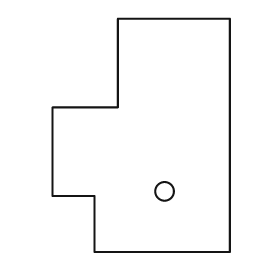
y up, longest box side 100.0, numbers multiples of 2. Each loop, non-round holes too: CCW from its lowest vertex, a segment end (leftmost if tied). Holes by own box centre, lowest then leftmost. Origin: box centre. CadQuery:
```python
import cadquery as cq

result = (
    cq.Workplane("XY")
    .moveTo(-20.0, -50.0)
    .lineTo(38.0, -50.0)
    .lineTo(38.0, 50.0)
    .lineTo(-10.0, 50.0)
    .lineTo(-10.0, 12.0)
    .lineTo(-38.0, 12.0)
    .lineTo(-38.0, -26.0)
    .lineTo(-20.0, -26.0)
    .close()
    .moveTo(10.0, -24.0)
    .circle(4.0)
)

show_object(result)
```